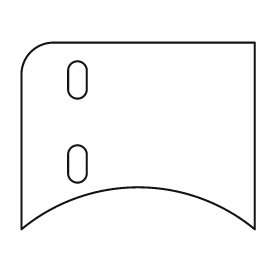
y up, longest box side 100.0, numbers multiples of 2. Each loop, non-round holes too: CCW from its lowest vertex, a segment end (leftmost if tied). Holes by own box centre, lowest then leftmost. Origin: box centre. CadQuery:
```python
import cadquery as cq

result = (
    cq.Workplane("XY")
    .moveTo(-50.0, -40.0)
    .threePointArc((0.0, -22.0), (50.0, -40.0))
    .lineTo(50.0, 40.0)
    .lineTo(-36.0, 40.0)
    .threePointArc((-46.0, 36.0), (-50.0, 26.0))
    .close()
    .moveTo(-30.0, -16.0)
    .threePointArc((-26.0, -20.0), (-22.0, -16.0))
    .lineTo(-22.0, -8.0)
    .threePointArc((-26.0, -4.0), (-30.0, -8.0))
    .close()
    .moveTo(-30.0, 20.0)
    .threePointArc((-26.0, 16.0), (-22.0, 20.0))
    .lineTo(-22.0, 28.0)
    .threePointArc((-26.0, 32.0), (-30.0, 28.0))
    .close()
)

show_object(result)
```